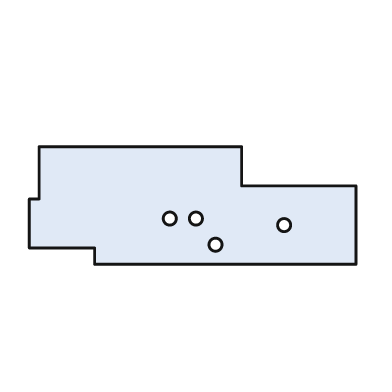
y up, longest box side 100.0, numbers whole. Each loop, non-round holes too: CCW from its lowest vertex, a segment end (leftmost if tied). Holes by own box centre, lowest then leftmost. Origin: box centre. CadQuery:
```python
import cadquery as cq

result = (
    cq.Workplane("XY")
    .moveTo(-30.0, -18.0)
    .lineTo(50.0, -18.0)
    .lineTo(50.0, 6.0)
    .lineTo(15.0, 6.0)
    .lineTo(15.0, 18.0)
    .lineTo(-47.0, 18.0)
    .lineTo(-47.0, 2.0)
    .lineTo(-50.0, 2.0)
    .lineTo(-50.0, -13.0)
    .lineTo(-30.0, -13.0)
    .close()
    .moveTo(7.0, -12.0)
    .circle(2.0)
    .moveTo(28.0, -6.0)
    .circle(2.0)
    .moveTo(-7.0, -4.0)
    .circle(2.0)
    .moveTo(1.0, -4.0)
    .circle(2.0)
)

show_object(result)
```